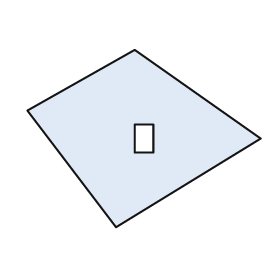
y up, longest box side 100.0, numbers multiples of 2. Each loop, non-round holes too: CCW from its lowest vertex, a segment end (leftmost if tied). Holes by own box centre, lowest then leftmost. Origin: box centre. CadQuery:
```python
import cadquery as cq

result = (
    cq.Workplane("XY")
    .moveTo(-12.0, -38.0)
    .lineTo(50.0, 0.0)
    .lineTo(-4.0, 38.0)
    .lineTo(-50.0, 12.0)
    .close()
    .moveTo(-4.0, -6.0)
    .lineTo(4.0, -6.0)
    .lineTo(4.0, 6.0)
    .lineTo(-4.0, 6.0)
    .close()
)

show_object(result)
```